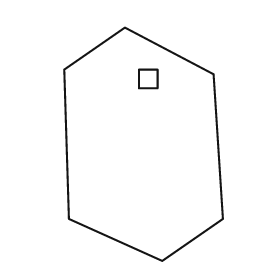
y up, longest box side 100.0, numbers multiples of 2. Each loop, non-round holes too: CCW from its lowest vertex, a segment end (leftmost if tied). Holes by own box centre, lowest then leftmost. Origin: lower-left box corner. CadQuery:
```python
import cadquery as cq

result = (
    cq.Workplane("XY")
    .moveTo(42.0, 0.0)
    .lineTo(68.0, 18.0)
    .lineTo(64.0, 80.0)
    .lineTo(26.0, 100.0)
    .lineTo(0.0, 82.0)
    .lineTo(2.0, 18.0)
    .close()
    .moveTo(32.0, 74.0)
    .lineTo(40.0, 74.0)
    .lineTo(40.0, 82.0)
    .lineTo(32.0, 82.0)
    .close()
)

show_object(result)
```